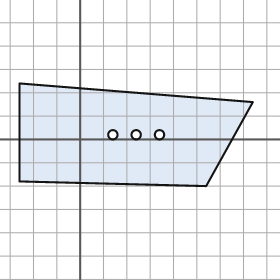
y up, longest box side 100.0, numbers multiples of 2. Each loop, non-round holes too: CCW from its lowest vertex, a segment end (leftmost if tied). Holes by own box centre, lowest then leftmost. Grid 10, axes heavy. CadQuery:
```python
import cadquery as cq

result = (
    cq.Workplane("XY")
    .moveTo(54.0, -20.0)
    .lineTo(74.0, 16.0)
    .lineTo(-26.0, 24.0)
    .lineTo(-26.0, -18.0)
    .close()
    .moveTo(14.0, 2.0)
    .circle(2.0)
    .moveTo(24.0, 2.0)
    .circle(2.0)
    .moveTo(34.0, 2.0)
    .circle(2.0)
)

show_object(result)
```